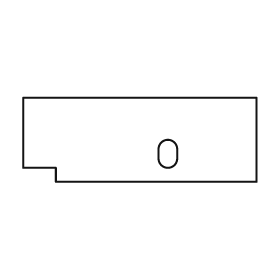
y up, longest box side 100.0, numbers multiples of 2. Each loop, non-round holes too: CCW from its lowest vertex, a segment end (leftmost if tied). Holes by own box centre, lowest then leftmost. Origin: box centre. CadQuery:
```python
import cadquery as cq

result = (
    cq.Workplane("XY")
    .moveTo(-36.0, -18.0)
    .lineTo(50.0, -18.0)
    .lineTo(50.0, 18.0)
    .lineTo(-50.0, 18.0)
    .lineTo(-50.0, -12.0)
    .lineTo(-36.0, -12.0)
    .close()
    .moveTo(8.0, -8.0)
    .threePointArc((12.0, -12.0), (16.0, -8.0))
    .lineTo(16.0, -4.0)
    .threePointArc((12.0, 0.0), (8.0, -4.0))
    .close()
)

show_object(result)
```